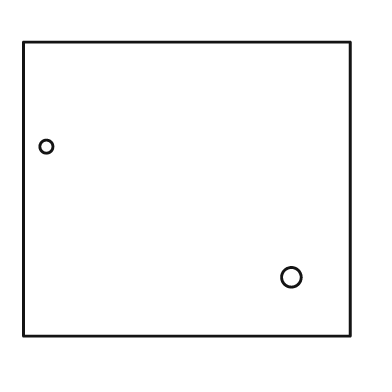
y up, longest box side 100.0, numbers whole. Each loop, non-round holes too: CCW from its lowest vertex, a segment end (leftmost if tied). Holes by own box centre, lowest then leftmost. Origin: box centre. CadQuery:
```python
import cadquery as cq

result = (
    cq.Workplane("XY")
    .moveTo(-50.0, -45.0)
    .lineTo(50.0, -45.0)
    .lineTo(50.0, 45.0)
    .lineTo(-50.0, 45.0)
    .close()
    .moveTo(32.0, -27.0)
    .circle(3.0)
    .moveTo(-43.0, 13.0)
    .circle(2.0)
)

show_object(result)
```